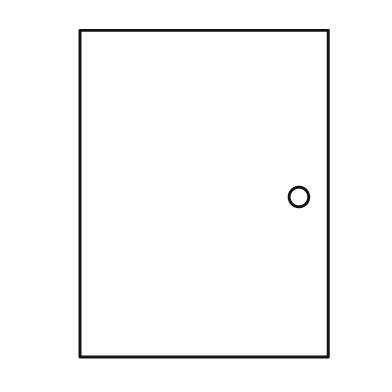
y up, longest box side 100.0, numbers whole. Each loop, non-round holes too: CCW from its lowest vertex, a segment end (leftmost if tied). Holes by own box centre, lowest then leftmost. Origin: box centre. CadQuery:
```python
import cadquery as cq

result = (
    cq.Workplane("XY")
    .moveTo(-38.0, -50.0)
    .lineTo(38.0, -50.0)
    .lineTo(38.0, 50.0)
    .lineTo(-38.0, 50.0)
    .close()
    .moveTo(29.0, -1.0)
    .circle(3.0)
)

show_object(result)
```